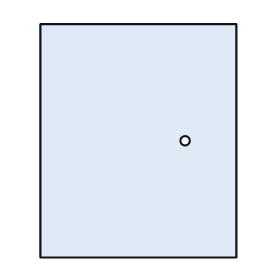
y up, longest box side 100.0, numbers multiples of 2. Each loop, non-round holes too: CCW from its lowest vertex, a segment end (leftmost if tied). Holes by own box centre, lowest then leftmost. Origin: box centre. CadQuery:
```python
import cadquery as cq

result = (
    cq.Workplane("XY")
    .moveTo(-42.0, -50.0)
    .lineTo(42.0, -50.0)
    .lineTo(42.0, 50.0)
    .lineTo(-42.0, 50.0)
    .close()
    .moveTo(20.0, 0.0)
    .circle(2.0)
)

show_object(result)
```